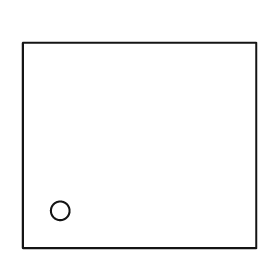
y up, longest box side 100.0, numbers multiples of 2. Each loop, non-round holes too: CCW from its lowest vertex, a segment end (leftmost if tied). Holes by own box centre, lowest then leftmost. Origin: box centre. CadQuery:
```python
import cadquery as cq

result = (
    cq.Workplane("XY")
    .moveTo(-50.0, -44.0)
    .lineTo(50.0, -44.0)
    .lineTo(50.0, 44.0)
    .lineTo(-50.0, 44.0)
    .close()
    .moveTo(-34.0, -28.0)
    .circle(4.0)
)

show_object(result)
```